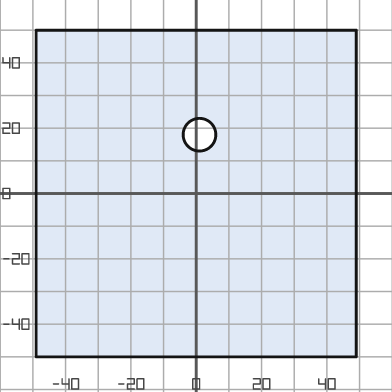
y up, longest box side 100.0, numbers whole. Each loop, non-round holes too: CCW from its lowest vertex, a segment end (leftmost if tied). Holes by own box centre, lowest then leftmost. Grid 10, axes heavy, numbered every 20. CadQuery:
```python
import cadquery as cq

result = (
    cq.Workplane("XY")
    .moveTo(-49.0, -50.0)
    .lineTo(49.0, -50.0)
    .lineTo(49.0, 50.0)
    .lineTo(-49.0, 50.0)
    .close()
    .moveTo(1.0, 18.0)
    .circle(5.0)
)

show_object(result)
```